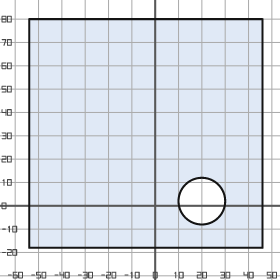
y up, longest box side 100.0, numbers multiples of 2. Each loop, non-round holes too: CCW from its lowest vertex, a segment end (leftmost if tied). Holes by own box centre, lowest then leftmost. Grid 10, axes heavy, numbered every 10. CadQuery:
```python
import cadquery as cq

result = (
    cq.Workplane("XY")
    .moveTo(-54.0, -18.0)
    .lineTo(46.0, -18.0)
    .lineTo(46.0, 80.0)
    .lineTo(-54.0, 80.0)
    .close()
    .moveTo(20.0, 2.0)
    .circle(10.0)
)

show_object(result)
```